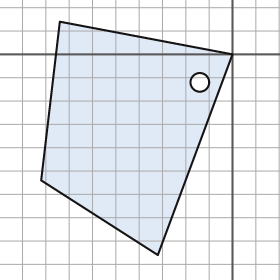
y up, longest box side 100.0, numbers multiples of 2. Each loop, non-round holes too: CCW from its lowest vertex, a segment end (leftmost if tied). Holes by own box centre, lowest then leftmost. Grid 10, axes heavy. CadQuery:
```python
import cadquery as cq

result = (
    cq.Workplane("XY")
    .moveTo(-32.0, -86.0)
    .lineTo(0.0, 0.0)
    .lineTo(-74.0, 14.0)
    .lineTo(-82.0, -54.0)
    .close()
    .moveTo(-14.0, -12.0)
    .circle(4.0)
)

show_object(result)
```